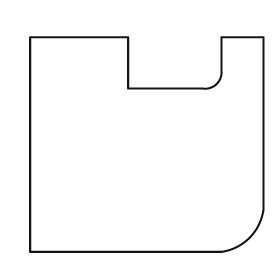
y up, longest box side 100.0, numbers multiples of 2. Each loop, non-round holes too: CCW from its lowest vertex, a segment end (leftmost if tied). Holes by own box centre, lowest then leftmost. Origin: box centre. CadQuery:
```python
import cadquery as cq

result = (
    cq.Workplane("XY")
    .moveTo(-50.0, -46.0)
    .lineTo(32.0, -46.0)
    .threePointArc((44.0, -40.0), (50.0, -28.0))
    .lineTo(50.0, 46.0)
    .lineTo(32.0, 46.0)
    .lineTo(32.0, 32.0)
    .threePointArc((30.0, 26.0), (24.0, 24.0))
    .lineTo(-8.0, 24.0)
    .lineTo(-8.0, 46.0)
    .lineTo(-50.0, 46.0)
    .close()
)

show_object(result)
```